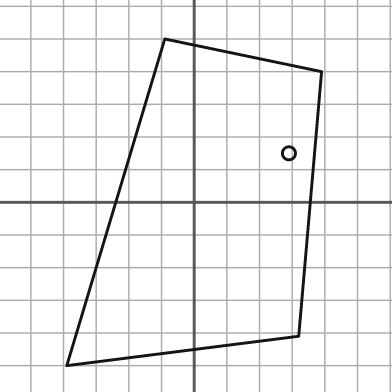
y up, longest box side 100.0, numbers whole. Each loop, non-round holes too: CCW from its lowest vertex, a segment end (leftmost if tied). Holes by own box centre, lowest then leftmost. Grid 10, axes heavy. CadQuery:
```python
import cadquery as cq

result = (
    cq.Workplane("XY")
    .moveTo(-39.0, -50.0)
    .lineTo(32.0, -41.0)
    .lineTo(39.0, 40.0)
    .lineTo(-9.0, 50.0)
    .close()
    .moveTo(29.0, 15.0)
    .circle(2.0)
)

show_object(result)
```